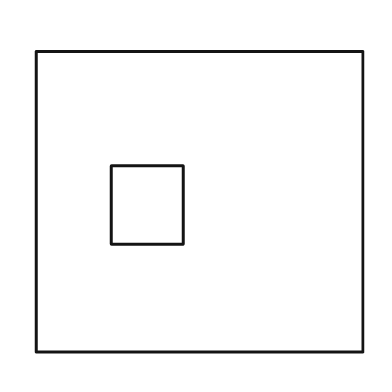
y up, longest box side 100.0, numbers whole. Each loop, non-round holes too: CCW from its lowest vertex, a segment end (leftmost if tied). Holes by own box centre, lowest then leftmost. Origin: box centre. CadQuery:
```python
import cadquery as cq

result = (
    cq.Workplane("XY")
    .moveTo(-50.0, -46.0)
    .lineTo(50.0, -46.0)
    .lineTo(50.0, 46.0)
    .lineTo(-50.0, 46.0)
    .close()
    .moveTo(-27.0, -13.0)
    .lineTo(-5.0, -13.0)
    .lineTo(-5.0, 11.0)
    .lineTo(-27.0, 11.0)
    .close()
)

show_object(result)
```